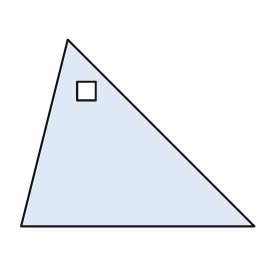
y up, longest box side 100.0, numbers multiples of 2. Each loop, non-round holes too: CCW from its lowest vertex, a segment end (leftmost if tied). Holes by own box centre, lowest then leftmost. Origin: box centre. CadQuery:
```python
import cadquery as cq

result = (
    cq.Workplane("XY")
    .moveTo(-50.0, -40.0)
    .lineTo(50.0, -40.0)
    .lineTo(-30.0, 40.0)
    .close()
    .moveTo(-26.0, 14.0)
    .lineTo(-18.0, 14.0)
    .lineTo(-18.0, 22.0)
    .lineTo(-26.0, 22.0)
    .close()
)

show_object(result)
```